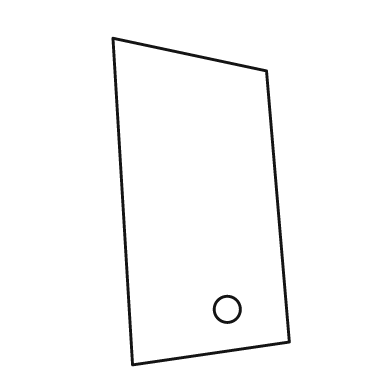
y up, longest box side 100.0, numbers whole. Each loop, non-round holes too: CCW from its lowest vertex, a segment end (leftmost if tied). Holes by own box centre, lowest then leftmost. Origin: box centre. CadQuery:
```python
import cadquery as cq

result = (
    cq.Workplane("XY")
    .moveTo(-21.0, -50.0)
    .lineTo(27.0, -43.0)
    .lineTo(20.0, 40.0)
    .lineTo(-27.0, 50.0)
    .close()
    .moveTo(8.0, -33.0)
    .circle(4.0)
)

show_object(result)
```